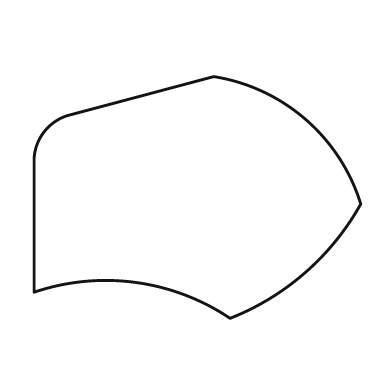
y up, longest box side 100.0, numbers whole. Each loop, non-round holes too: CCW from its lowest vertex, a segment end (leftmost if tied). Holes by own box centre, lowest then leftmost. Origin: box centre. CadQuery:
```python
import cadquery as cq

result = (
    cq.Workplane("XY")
    .moveTo(10.0, -37.0)
    .threePointArc((33.0, -23.0), (50.0, -2.0))
    .threePointArc((33.0, 24.0), (5.0, 37.0))
    .lineTo(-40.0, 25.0)
    .threePointArc((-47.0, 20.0), (-50.0, 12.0))
    .lineTo(-50.0, -29.0)
    .threePointArc((-19.0, -26.0), (10.0, -37.0))
    .close()
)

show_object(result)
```